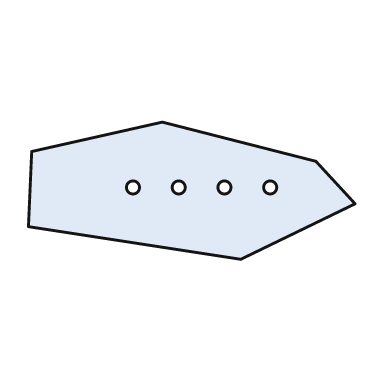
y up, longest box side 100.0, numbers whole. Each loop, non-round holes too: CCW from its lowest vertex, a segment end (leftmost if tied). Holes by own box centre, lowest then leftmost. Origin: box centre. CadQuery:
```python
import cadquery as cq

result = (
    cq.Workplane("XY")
    .moveTo(15.0, -21.0)
    .lineTo(50.0, -4.0)
    .lineTo(38.0, 9.0)
    .lineTo(-9.0, 21.0)
    .lineTo(-49.0, 12.0)
    .lineTo(-50.0, -11.0)
    .close()
    .moveTo(-18.0, 1.0)
    .circle(2.0)
    .moveTo(-4.0, 1.0)
    .circle(2.0)
    .moveTo(10.0, 1.0)
    .circle(2.0)
    .moveTo(24.0, 1.0)
    .circle(2.0)
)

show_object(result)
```